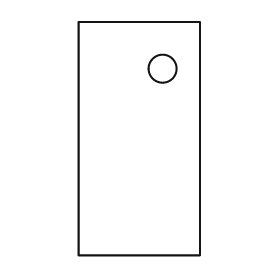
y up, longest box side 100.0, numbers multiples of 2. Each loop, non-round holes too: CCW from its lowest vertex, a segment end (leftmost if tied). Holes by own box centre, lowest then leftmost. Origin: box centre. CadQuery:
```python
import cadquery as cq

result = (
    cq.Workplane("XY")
    .moveTo(-26.0, -50.0)
    .lineTo(26.0, -50.0)
    .lineTo(26.0, 50.0)
    .lineTo(-26.0, 50.0)
    .close()
    .moveTo(10.0, 30.0)
    .circle(6.0)
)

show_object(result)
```